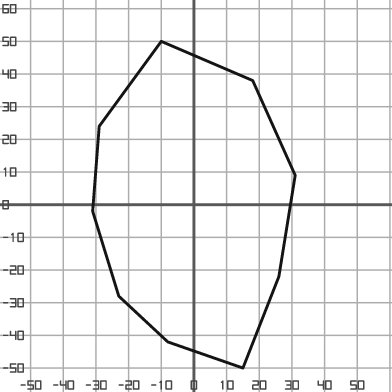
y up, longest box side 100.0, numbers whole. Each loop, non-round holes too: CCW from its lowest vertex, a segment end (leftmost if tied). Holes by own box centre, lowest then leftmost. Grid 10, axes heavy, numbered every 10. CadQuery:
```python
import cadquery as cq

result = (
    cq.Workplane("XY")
    .moveTo(15.0, -50.0)
    .lineTo(26.0, -22.0)
    .lineTo(31.0, 9.0)
    .lineTo(18.0, 38.0)
    .lineTo(-10.0, 50.0)
    .lineTo(-29.0, 24.0)
    .lineTo(-31.0, -2.0)
    .lineTo(-23.0, -28.0)
    .lineTo(-8.0, -42.0)
    .close()
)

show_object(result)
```